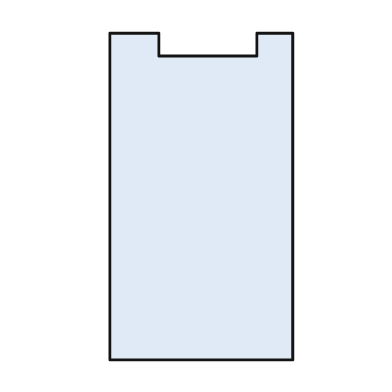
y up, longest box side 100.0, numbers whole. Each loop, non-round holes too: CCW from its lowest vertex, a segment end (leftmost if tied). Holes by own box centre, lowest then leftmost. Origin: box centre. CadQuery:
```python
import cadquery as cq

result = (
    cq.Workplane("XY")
    .moveTo(-28.0, -50.0)
    .lineTo(28.0, -50.0)
    .lineTo(28.0, 50.0)
    .lineTo(17.0, 50.0)
    .lineTo(17.0, 43.0)
    .lineTo(-13.0, 43.0)
    .lineTo(-13.0, 50.0)
    .lineTo(-28.0, 50.0)
    .close()
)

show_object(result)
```